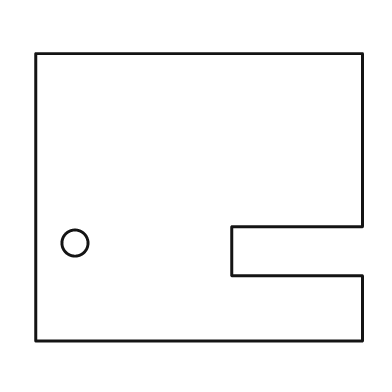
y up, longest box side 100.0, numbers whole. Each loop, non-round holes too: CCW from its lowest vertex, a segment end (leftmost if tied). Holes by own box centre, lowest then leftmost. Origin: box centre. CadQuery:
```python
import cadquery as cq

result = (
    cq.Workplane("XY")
    .moveTo(-50.0, -44.0)
    .lineTo(50.0, -44.0)
    .lineTo(50.0, -24.0)
    .lineTo(10.0, -24.0)
    .lineTo(10.0, -9.0)
    .lineTo(50.0, -9.0)
    .lineTo(50.0, 44.0)
    .lineTo(-50.0, 44.0)
    .close()
    .moveTo(-38.0, -14.0)
    .circle(4.0)
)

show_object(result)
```